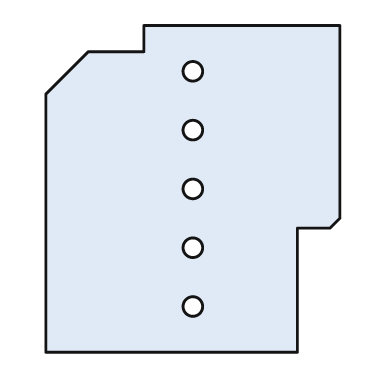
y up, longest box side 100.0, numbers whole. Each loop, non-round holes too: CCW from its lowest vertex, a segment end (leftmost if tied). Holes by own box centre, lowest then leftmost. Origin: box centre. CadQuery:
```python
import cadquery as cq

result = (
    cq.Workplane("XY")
    .moveTo(-45.0, -50.0)
    .lineTo(32.0, -50.0)
    .lineTo(32.0, -12.0)
    .lineTo(42.0, -12.0)
    .lineTo(45.0, -9.0)
    .lineTo(45.0, 50.0)
    .lineTo(-15.0, 50.0)
    .lineTo(-15.0, 42.0)
    .lineTo(-32.0, 42.0)
    .lineTo(-45.0, 29.0)
    .close()
    .moveTo(0.0, -36.0)
    .circle(3.0)
    .moveTo(0.0, -18.0)
    .circle(3.0)
    .moveTo(0.0, 0.0)
    .circle(3.0)
    .moveTo(0.0, 18.0)
    .circle(3.0)
    .moveTo(0.0, 36.0)
    .circle(3.0)
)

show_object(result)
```